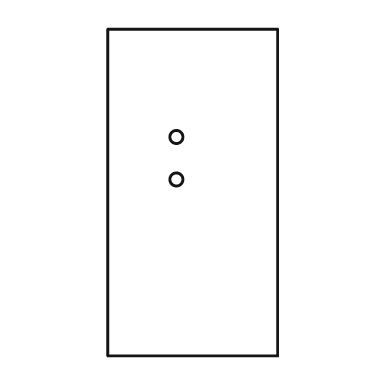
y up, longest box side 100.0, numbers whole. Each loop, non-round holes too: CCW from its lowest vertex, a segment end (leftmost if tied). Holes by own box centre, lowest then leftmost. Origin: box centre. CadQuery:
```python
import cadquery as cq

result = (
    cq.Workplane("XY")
    .moveTo(-26.0, -50.0)
    .lineTo(26.0, -50.0)
    .lineTo(26.0, 50.0)
    .lineTo(-26.0, 50.0)
    .close()
    .moveTo(-5.0, 4.0)
    .circle(2.0)
    .moveTo(-5.0, 17.0)
    .circle(2.0)
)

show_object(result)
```